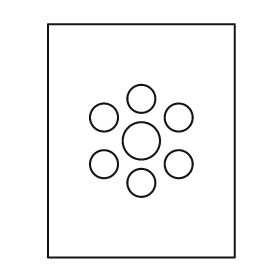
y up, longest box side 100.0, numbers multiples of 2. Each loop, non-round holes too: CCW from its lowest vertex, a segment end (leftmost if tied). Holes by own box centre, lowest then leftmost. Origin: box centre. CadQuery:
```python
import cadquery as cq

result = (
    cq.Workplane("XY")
    .moveTo(-40.0, -50.0)
    .lineTo(40.0, -50.0)
    .lineTo(40.0, 50.0)
    .lineTo(-40.0, 50.0)
    .close()
    .moveTo(0.0, -18.0)
    .circle(6.0)
    .moveTo(-16.0, -10.0)
    .circle(6.0)
    .moveTo(16.0, -10.0)
    .circle(6.0)
    .moveTo(0.0, 0.0)
    .circle(8.0)
    .moveTo(-16.0, 10.0)
    .circle(6.0)
    .moveTo(16.0, 10.0)
    .circle(6.0)
    .moveTo(0.0, 18.0)
    .circle(6.0)
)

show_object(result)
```